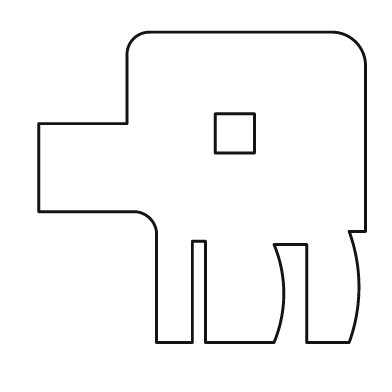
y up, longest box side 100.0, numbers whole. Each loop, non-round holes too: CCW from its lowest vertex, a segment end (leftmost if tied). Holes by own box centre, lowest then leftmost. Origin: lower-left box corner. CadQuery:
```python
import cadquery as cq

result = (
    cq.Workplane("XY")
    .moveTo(36.0, 0.0)
    .lineTo(47.0, 0.0)
    .lineTo(47.0, 31.0)
    .lineTo(51.0, 31.0)
    .lineTo(51.0, 0.0)
    .lineTo(72.0, 0.0)
    .threePointArc((75.0, 15.0), (72.0, 30.0))
    .lineTo(82.0, 30.0)
    .lineTo(82.0, 0.0)
    .lineTo(95.0, 0.0)
    .threePointArc((98.0, 17.0), (95.0, 34.0))
    .lineTo(100.0, 34.0)
    .lineTo(100.0, 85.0)
    .threePointArc((97.0, 92.0), (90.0, 95.0))
    .lineTo(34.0, 95.0)
    .threePointArc((29.0, 93.0), (27.0, 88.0))
    .lineTo(27.0, 67.0)
    .lineTo(0.0, 67.0)
    .lineTo(0.0, 40.0)
    .lineTo(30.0, 40.0)
    .threePointArc((34.0, 38.0), (36.0, 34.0))
    .close()
    .moveTo(54.0, 58.0)
    .lineTo(66.0, 58.0)
    .lineTo(66.0, 70.0)
    .lineTo(54.0, 70.0)
    .close()
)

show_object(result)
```